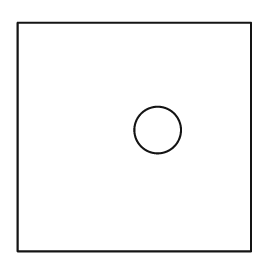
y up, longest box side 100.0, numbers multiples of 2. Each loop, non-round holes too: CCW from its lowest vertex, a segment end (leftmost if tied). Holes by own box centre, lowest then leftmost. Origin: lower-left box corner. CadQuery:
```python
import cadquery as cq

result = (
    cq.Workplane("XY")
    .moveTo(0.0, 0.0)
    .lineTo(100.0, 0.0)
    .lineTo(100.0, 98.0)
    .lineTo(0.0, 98.0)
    .close()
    .moveTo(60.0, 52.0)
    .circle(10.0)
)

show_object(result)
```